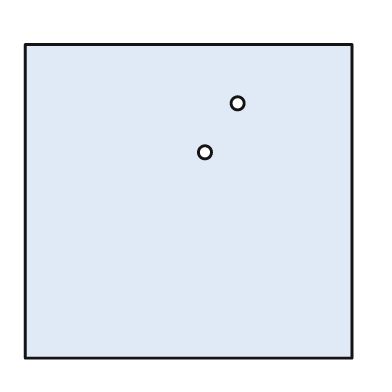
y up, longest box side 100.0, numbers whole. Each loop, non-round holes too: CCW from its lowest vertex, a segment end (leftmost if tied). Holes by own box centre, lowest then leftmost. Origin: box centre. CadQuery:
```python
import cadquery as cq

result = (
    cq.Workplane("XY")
    .moveTo(-50.0, -48.0)
    .lineTo(50.0, -48.0)
    .lineTo(50.0, 48.0)
    .lineTo(-50.0, 48.0)
    .close()
    .moveTo(5.0, 15.0)
    .circle(2.0)
    .moveTo(15.0, 30.0)
    .circle(2.0)
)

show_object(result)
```